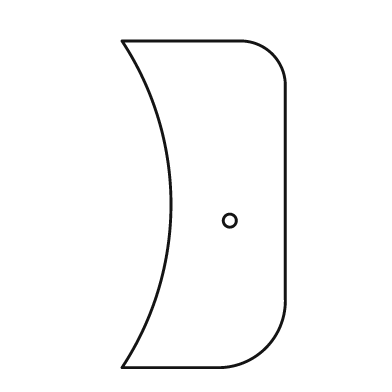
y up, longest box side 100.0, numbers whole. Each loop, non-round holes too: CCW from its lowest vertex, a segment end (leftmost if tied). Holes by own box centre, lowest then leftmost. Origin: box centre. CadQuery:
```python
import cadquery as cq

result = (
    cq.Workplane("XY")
    .moveTo(-25.0, -50.0)
    .lineTo(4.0, -50.0)
    .threePointArc((19.0, -44.0), (25.0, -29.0))
    .lineTo(25.0, 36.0)
    .threePointArc((21.0, 46.0), (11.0, 50.0))
    .lineTo(-25.0, 50.0)
    .threePointArc((-10.0, 0.0), (-25.0, -50.0))
    .close()
    .moveTo(8.0, -5.0)
    .circle(2.0)
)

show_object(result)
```